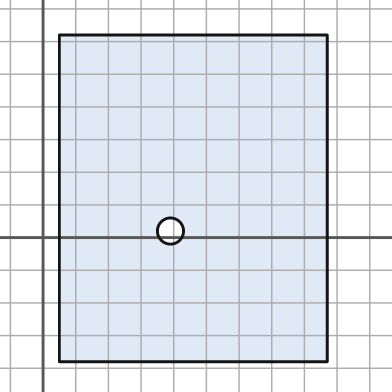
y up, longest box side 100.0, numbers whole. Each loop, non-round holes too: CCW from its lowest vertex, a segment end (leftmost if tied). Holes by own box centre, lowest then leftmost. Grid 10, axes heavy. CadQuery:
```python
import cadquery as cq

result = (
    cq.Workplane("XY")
    .moveTo(5.0, -38.0)
    .lineTo(87.0, -38.0)
    .lineTo(87.0, 62.0)
    .lineTo(5.0, 62.0)
    .close()
    .moveTo(39.0, 2.0)
    .circle(4.0)
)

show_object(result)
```